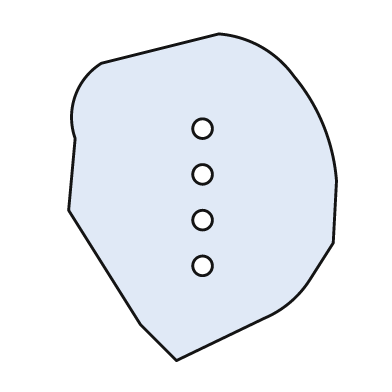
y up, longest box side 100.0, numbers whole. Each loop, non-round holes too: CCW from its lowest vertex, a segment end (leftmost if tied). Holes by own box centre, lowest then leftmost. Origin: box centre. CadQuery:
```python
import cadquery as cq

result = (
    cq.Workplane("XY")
    .moveTo(-8.0, -50.0)
    .lineTo(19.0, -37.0)
    .threePointArc((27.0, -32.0), (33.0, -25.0))
    .lineTo(40.0, -14.0)
    .lineTo(41.0, 5.0)
    .threePointArc((37.0, 22.0), (28.0, 37.0))
    .threePointArc((18.0, 46.0), (5.0, 50.0))
    .lineTo(-31.0, 41.0)
    .threePointArc((-39.0, 31.0), (-39.0, 18.0))
    .lineTo(-41.0, -4.0)
    .lineTo(-19.0, -39.0)
    .close()
    .moveTo(0.0, -21.0)
    .circle(3.0)
    .moveTo(0.0, -7.0)
    .circle(3.0)
    .moveTo(0.0, 7.0)
    .circle(3.0)
    .moveTo(0.0, 21.0)
    .circle(3.0)
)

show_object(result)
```